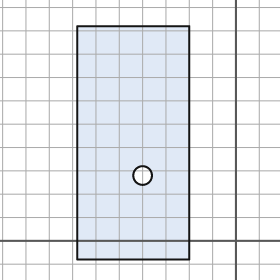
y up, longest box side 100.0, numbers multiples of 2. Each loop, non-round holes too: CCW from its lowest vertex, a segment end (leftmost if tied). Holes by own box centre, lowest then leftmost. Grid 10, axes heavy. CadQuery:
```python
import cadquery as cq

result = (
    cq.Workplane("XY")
    .moveTo(-68.0, -8.0)
    .lineTo(-20.0, -8.0)
    .lineTo(-20.0, 92.0)
    .lineTo(-68.0, 92.0)
    .close()
    .moveTo(-40.0, 28.0)
    .circle(4.0)
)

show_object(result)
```